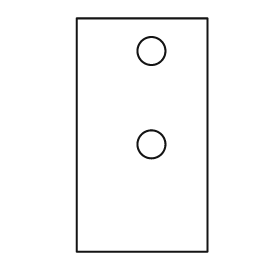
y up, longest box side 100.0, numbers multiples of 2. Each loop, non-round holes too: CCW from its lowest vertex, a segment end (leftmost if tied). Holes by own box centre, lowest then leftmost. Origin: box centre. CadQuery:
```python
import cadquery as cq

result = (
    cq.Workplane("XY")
    .moveTo(-28.0, -50.0)
    .lineTo(28.0, -50.0)
    .lineTo(28.0, 50.0)
    .lineTo(-28.0, 50.0)
    .close()
    .moveTo(4.0, -4.0)
    .circle(6.0)
    .moveTo(4.0, 36.0)
    .circle(6.0)
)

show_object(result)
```